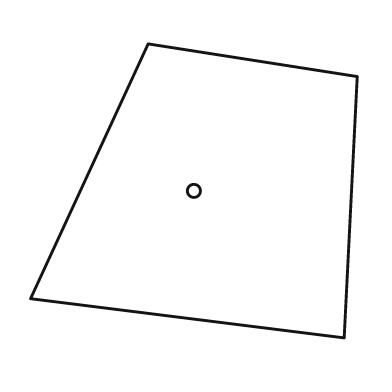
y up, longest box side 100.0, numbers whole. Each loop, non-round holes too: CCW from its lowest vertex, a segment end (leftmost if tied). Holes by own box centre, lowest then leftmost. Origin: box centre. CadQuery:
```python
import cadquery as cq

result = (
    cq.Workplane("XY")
    .moveTo(46.0, -45.0)
    .lineTo(50.0, 35.0)
    .lineTo(-14.0, 45.0)
    .lineTo(-50.0, -33.0)
    .close()
    .moveTo(0.0, 0.0)
    .circle(2.0)
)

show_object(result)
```